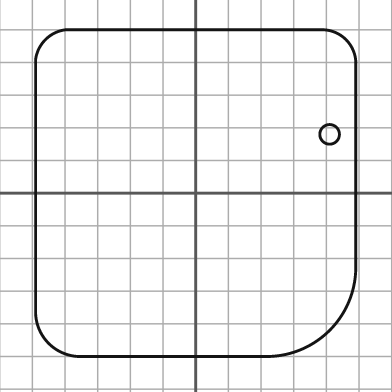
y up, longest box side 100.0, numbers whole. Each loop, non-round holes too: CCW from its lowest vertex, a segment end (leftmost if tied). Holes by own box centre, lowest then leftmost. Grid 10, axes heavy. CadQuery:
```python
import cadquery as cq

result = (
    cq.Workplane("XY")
    .moveTo(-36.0, -50.0)
    .lineTo(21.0, -50.0)
    .threePointArc((41.0, -42.0), (49.0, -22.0))
    .lineTo(49.0, 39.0)
    .threePointArc((46.0, 47.0), (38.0, 50.0))
    .lineTo(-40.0, 50.0)
    .threePointArc((-46.0, 47.0), (-49.0, 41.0))
    .lineTo(-49.0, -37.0)
    .threePointArc((-45.0, -46.0), (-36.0, -50.0))
    .close()
    .moveTo(41.0, 18.0)
    .circle(3.0)
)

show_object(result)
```